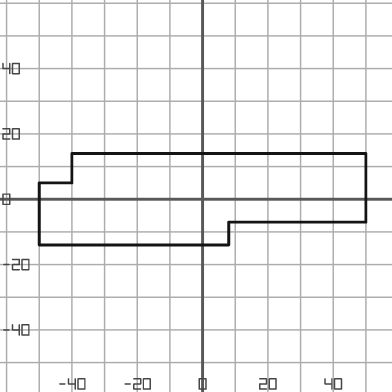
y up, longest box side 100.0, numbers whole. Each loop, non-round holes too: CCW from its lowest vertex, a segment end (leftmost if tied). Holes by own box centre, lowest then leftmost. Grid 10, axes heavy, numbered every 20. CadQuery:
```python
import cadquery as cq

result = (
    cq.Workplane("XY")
    .moveTo(-50.0, -14.0)
    .lineTo(8.0, -14.0)
    .lineTo(8.0, -7.0)
    .lineTo(50.0, -7.0)
    .lineTo(50.0, 14.0)
    .lineTo(-40.0, 14.0)
    .lineTo(-40.0, 5.0)
    .lineTo(-50.0, 5.0)
    .close()
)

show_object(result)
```